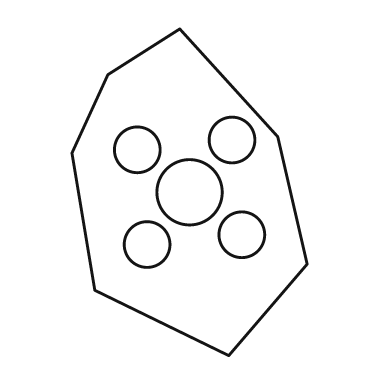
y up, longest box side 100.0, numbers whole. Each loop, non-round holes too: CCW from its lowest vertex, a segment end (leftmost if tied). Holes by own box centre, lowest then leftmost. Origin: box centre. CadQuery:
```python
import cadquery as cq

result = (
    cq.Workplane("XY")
    .moveTo(12.0, -50.0)
    .lineTo(36.0, -22.0)
    .lineTo(27.0, 17.0)
    .lineTo(-3.0, 50.0)
    .lineTo(-25.0, 36.0)
    .lineTo(-36.0, 12.0)
    .lineTo(-29.0, -30.0)
    .close()
    .moveTo(-13.0, -16.0)
    .circle(7.0)
    .moveTo(16.0, -13.0)
    .circle(7.0)
    .moveTo(0.0, 0.0)
    .circle(10.0)
    .moveTo(-16.0, 13.0)
    .circle(7.0)
    .moveTo(13.0, 16.0)
    .circle(7.0)
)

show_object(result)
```